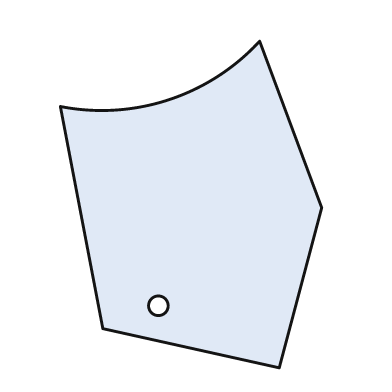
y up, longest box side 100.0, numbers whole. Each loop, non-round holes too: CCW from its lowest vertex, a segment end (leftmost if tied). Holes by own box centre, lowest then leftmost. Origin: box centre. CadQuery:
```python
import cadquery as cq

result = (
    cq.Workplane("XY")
    .moveTo(27.0, -50.0)
    .lineTo(40.0, -1.0)
    .lineTo(21.0, 50.0)
    .threePointArc((-7.0, 32.0), (-40.0, 30.0))
    .lineTo(-27.0, -38.0)
    .close()
    .moveTo(-10.0, -31.0)
    .circle(3.0)
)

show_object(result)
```